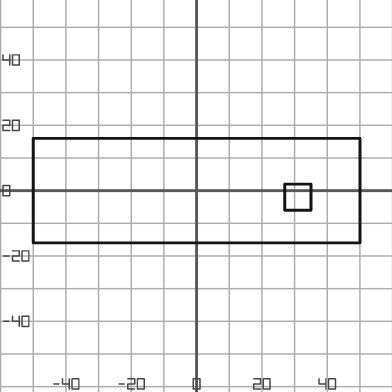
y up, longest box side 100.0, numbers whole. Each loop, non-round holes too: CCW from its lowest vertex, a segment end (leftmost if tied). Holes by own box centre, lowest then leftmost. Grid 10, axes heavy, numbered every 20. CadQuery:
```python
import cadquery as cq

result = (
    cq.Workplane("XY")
    .moveTo(-50.0, -16.0)
    .lineTo(50.0, -16.0)
    .lineTo(50.0, 16.0)
    .lineTo(-50.0, 16.0)
    .close()
    .moveTo(27.0, -6.0)
    .lineTo(35.0, -6.0)
    .lineTo(35.0, 2.0)
    .lineTo(27.0, 2.0)
    .close()
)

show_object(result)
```